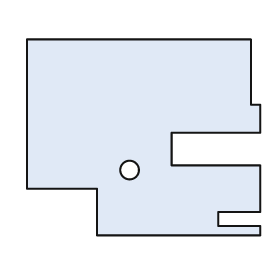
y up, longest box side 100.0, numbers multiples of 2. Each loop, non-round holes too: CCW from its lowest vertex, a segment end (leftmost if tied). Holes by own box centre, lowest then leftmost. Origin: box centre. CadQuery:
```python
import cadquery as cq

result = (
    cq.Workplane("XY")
    .moveTo(-20.0, -42.0)
    .lineTo(50.0, -42.0)
    .lineTo(50.0, -38.0)
    .lineTo(32.0, -38.0)
    .lineTo(32.0, -32.0)
    .lineTo(50.0, -32.0)
    .lineTo(50.0, -12.0)
    .lineTo(12.0, -12.0)
    .lineTo(12.0, 2.0)
    .lineTo(50.0, 2.0)
    .lineTo(50.0, 14.0)
    .lineTo(46.0, 14.0)
    .lineTo(46.0, 42.0)
    .lineTo(-50.0, 42.0)
    .lineTo(-50.0, -22.0)
    .lineTo(-20.0, -22.0)
    .close()
    .moveTo(-6.0, -14.0)
    .circle(4.0)
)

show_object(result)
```